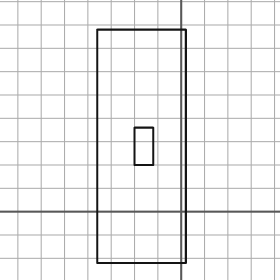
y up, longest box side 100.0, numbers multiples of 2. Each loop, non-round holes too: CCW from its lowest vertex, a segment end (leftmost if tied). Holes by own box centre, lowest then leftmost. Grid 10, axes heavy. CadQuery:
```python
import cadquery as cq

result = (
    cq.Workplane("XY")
    .moveTo(-36.0, -22.0)
    .lineTo(2.0, -22.0)
    .lineTo(2.0, 78.0)
    .lineTo(-36.0, 78.0)
    .close()
    .moveTo(-20.0, 20.0)
    .lineTo(-12.0, 20.0)
    .lineTo(-12.0, 36.0)
    .lineTo(-20.0, 36.0)
    .close()
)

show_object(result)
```